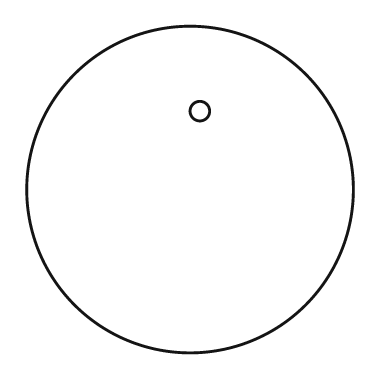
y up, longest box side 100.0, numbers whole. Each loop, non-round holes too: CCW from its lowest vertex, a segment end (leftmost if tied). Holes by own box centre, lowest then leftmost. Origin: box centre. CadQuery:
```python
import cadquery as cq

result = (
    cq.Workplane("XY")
    .moveTo(0.0, 0.0)
    .circle(50.0)
    .moveTo(3.0, 24.0)
    .circle(3.0)
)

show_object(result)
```